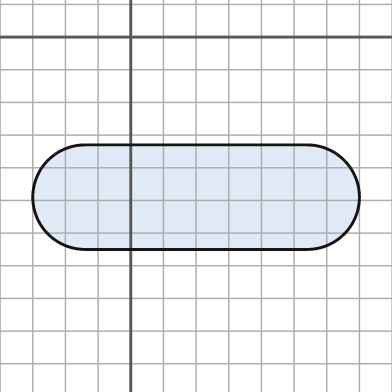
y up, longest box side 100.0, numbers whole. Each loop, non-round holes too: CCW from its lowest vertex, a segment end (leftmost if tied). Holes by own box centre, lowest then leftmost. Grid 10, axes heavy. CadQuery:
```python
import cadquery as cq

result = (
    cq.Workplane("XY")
    .moveTo(-14.0, -65.0)
    .lineTo(54.0, -65.0)
    .threePointArc((70.0, -49.0), (54.0, -33.0))
    .lineTo(-14.0, -33.0)
    .threePointArc((-30.0, -49.0), (-14.0, -65.0))
    .close()
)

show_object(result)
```